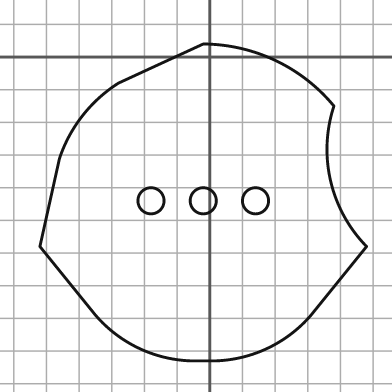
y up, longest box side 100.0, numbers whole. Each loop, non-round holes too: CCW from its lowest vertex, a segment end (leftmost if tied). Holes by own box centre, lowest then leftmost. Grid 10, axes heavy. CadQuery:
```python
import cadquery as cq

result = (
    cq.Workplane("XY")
    .moveTo(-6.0, -93.0)
    .lineTo(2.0, -93.0)
    .threePointArc((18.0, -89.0), (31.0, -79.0))
    .lineTo(48.0, -58.0)
    .threePointArc((37.0, -38.0), (38.0, -15.0))
    .threePointArc((20.0, -1.0), (-2.0, 4.0))
    .lineTo(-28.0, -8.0)
    .threePointArc((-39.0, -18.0), (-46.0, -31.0))
    .lineTo(-52.0, -58.0)
    .lineTo(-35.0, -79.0)
    .threePointArc((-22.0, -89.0), (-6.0, -93.0))
    .close()
    .moveTo(-18.0, -44.0)
    .circle(4.0)
    .moveTo(-2.0, -44.0)
    .circle(4.0)
    .moveTo(14.0, -44.0)
    .circle(4.0)
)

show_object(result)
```